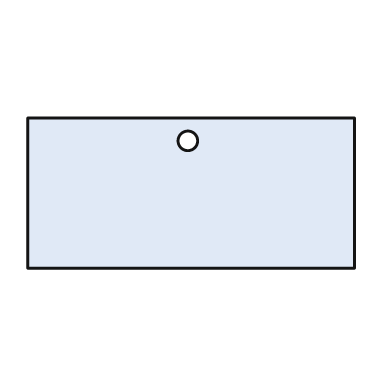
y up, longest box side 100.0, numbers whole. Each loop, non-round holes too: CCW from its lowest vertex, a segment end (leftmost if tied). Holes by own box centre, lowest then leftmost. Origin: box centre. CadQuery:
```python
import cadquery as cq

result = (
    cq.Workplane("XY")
    .moveTo(-50.0, -23.0)
    .lineTo(50.0, -23.0)
    .lineTo(50.0, 23.0)
    .lineTo(-50.0, 23.0)
    .close()
    .moveTo(-1.0, 16.0)
    .circle(3.0)
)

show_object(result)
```